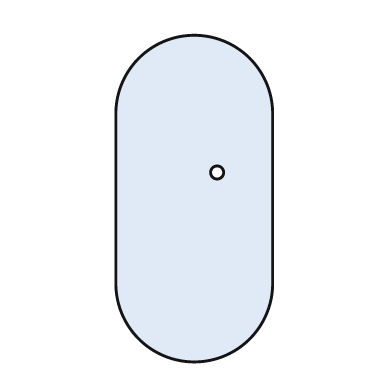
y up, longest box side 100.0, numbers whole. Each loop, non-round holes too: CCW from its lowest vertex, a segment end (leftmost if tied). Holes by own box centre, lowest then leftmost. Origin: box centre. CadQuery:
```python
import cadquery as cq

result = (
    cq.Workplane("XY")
    .moveTo(-24.0, -26.0)
    .threePointArc((0.0, -50.0), (24.0, -26.0))
    .lineTo(24.0, 26.0)
    .threePointArc((0.0, 50.0), (-24.0, 26.0))
    .close()
    .moveTo(7.0, 8.0)
    .circle(2.0)
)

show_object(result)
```